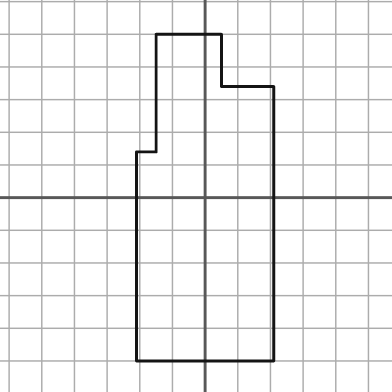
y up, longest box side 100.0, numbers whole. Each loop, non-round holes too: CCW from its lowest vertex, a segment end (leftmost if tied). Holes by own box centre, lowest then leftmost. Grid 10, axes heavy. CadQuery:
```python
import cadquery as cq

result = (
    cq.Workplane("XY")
    .moveTo(-21.0, -50.0)
    .lineTo(21.0, -50.0)
    .lineTo(21.0, 34.0)
    .lineTo(5.0, 34.0)
    .lineTo(5.0, 50.0)
    .lineTo(-15.0, 50.0)
    .lineTo(-15.0, 14.0)
    .lineTo(-21.0, 14.0)
    .close()
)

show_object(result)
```